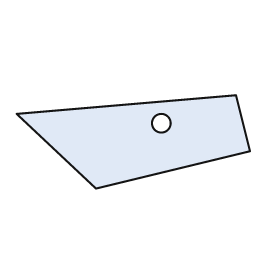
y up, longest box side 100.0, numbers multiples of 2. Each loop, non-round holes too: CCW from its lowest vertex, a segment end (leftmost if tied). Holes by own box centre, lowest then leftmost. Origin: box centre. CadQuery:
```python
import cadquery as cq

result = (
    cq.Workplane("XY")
    .moveTo(-16.0, -20.0)
    .lineTo(50.0, -4.0)
    .lineTo(44.0, 20.0)
    .lineTo(-50.0, 12.0)
    .close()
    .moveTo(12.0, 8.0)
    .circle(4.0)
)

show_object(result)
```